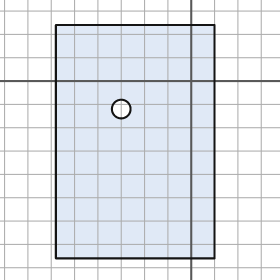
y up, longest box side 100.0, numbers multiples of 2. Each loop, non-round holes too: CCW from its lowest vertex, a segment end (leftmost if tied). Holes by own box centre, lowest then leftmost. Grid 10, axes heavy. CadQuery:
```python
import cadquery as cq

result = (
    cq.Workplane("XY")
    .moveTo(-58.0, -76.0)
    .lineTo(10.0, -76.0)
    .lineTo(10.0, 24.0)
    .lineTo(-58.0, 24.0)
    .close()
    .moveTo(-30.0, -12.0)
    .circle(4.0)
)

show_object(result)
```